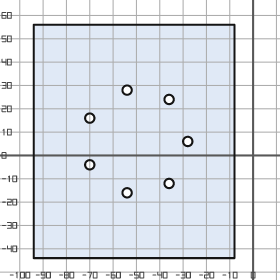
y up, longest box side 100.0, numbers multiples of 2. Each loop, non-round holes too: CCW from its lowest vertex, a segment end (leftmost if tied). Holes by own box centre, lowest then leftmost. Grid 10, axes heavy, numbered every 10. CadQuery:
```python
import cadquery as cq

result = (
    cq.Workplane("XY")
    .moveTo(-94.0, -44.0)
    .lineTo(-8.0, -44.0)
    .lineTo(-8.0, 56.0)
    .lineTo(-94.0, 56.0)
    .close()
    .moveTo(-54.0, -16.0)
    .circle(2.0)
    .moveTo(-36.0, -12.0)
    .circle(2.0)
    .moveTo(-70.0, -4.0)
    .circle(2.0)
    .moveTo(-28.0, 6.0)
    .circle(2.0)
    .moveTo(-70.0, 16.0)
    .circle(2.0)
    .moveTo(-36.0, 24.0)
    .circle(2.0)
    .moveTo(-54.0, 28.0)
    .circle(2.0)
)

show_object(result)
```